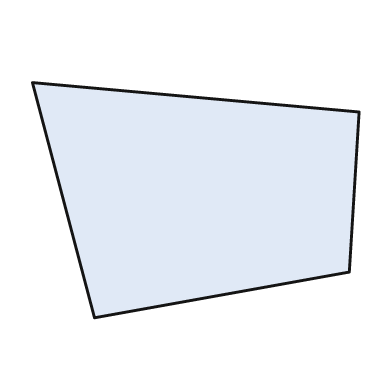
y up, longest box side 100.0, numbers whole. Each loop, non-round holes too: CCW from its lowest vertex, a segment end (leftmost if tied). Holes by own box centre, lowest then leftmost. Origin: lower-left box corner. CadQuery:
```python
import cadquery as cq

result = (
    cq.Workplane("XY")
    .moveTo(19.0, 0.0)
    .lineTo(97.0, 14.0)
    .lineTo(100.0, 63.0)
    .lineTo(0.0, 72.0)
    .close()
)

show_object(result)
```